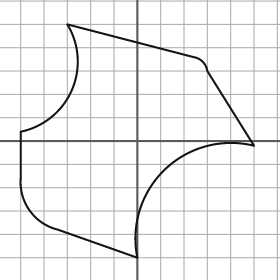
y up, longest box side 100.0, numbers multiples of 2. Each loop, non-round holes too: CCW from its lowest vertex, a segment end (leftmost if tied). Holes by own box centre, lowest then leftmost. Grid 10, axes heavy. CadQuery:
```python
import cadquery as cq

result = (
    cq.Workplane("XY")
    .moveTo(0.0, -50.0)
    .threePointArc((12.0, -12.0), (50.0, -2.0))
    .lineTo(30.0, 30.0)
    .threePointArc((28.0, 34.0), (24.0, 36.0))
    .lineTo(-30.0, 50.0)
    .threePointArc((-28.0, 22.0), (-50.0, 4.0))
    .lineTo(-50.0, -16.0)
    .threePointArc((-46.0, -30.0), (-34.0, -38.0))
    .close()
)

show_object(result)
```